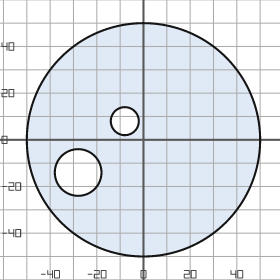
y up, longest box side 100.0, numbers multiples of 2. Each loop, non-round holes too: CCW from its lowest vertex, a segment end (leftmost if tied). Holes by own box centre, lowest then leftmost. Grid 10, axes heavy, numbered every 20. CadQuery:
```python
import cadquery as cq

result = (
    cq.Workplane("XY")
    .moveTo(0.0, 0.0)
    .circle(50.0)
    .moveTo(-28.0, -14.0)
    .circle(10.0)
    .moveTo(-8.0, 8.0)
    .circle(6.0)
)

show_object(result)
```